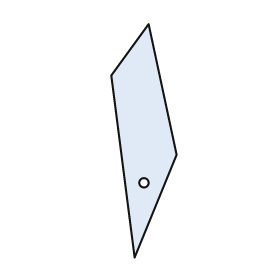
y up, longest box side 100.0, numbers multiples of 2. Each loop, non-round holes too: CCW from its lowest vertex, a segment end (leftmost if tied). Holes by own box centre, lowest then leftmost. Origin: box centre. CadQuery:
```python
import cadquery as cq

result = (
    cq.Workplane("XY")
    .moveTo(-4.0, -50.0)
    .lineTo(14.0, -6.0)
    .lineTo(2.0, 50.0)
    .lineTo(-14.0, 28.0)
    .close()
    .moveTo(0.0, -18.0)
    .circle(2.0)
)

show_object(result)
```